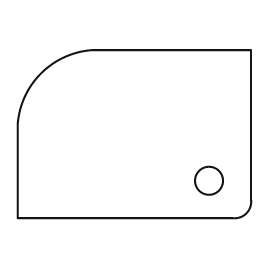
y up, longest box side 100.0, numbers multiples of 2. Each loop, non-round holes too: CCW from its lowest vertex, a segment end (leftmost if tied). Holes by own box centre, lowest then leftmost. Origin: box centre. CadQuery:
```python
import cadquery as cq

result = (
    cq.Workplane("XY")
    .moveTo(-50.0, -36.0)
    .lineTo(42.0, -36.0)
    .threePointArc((48.0, -34.0), (50.0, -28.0))
    .lineTo(50.0, 36.0)
    .lineTo(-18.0, 36.0)
    .threePointArc((-40.0, 26.0), (-50.0, 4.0))
    .close()
    .moveTo(32.0, -20.0)
    .circle(6.0)
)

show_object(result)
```